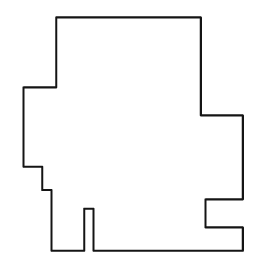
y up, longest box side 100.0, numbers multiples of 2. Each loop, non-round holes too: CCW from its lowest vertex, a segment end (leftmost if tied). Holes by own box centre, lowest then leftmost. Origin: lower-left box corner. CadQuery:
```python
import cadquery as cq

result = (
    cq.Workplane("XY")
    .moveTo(12.0, 0.0)
    .lineTo(26.0, 0.0)
    .lineTo(26.0, 18.0)
    .lineTo(30.0, 18.0)
    .lineTo(30.0, 0.0)
    .lineTo(94.0, 0.0)
    .lineTo(94.0, 10.0)
    .lineTo(78.0, 10.0)
    .lineTo(78.0, 22.0)
    .lineTo(94.0, 22.0)
    .lineTo(94.0, 58.0)
    .lineTo(76.0, 58.0)
    .lineTo(76.0, 100.0)
    .lineTo(14.0, 100.0)
    .lineTo(14.0, 70.0)
    .lineTo(0.0, 70.0)
    .lineTo(0.0, 36.0)
    .lineTo(8.0, 36.0)
    .lineTo(8.0, 26.0)
    .lineTo(12.0, 26.0)
    .close()
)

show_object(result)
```